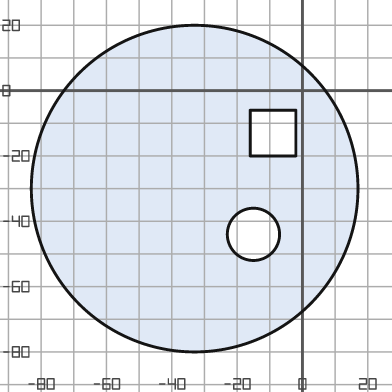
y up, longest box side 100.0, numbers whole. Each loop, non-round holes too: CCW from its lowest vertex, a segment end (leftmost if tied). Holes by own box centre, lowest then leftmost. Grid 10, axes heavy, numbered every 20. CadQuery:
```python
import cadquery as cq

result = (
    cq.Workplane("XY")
    .moveTo(-33.0, -30.0)
    .circle(50.0)
    .moveTo(-15.0, -44.0)
    .circle(8.0)
    .moveTo(-16.0, -20.0)
    .lineTo(-2.0, -20.0)
    .lineTo(-2.0, -6.0)
    .lineTo(-16.0, -6.0)
    .close()
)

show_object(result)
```